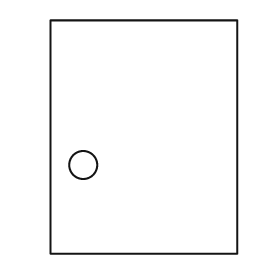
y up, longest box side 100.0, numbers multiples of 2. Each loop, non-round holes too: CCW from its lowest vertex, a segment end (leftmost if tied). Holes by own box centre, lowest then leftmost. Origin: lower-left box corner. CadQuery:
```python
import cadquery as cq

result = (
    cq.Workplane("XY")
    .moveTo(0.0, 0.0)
    .lineTo(80.0, 0.0)
    .lineTo(80.0, 100.0)
    .lineTo(0.0, 100.0)
    .close()
    .moveTo(14.0, 38.0)
    .circle(6.0)
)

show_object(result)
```